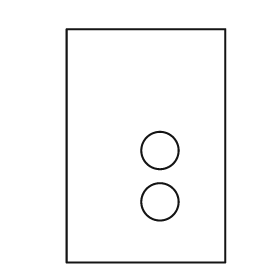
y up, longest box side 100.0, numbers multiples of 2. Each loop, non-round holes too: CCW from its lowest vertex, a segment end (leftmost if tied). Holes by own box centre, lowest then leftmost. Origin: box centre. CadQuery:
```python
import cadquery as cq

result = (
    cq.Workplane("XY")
    .moveTo(-34.0, -50.0)
    .lineTo(34.0, -50.0)
    .lineTo(34.0, 50.0)
    .lineTo(-34.0, 50.0)
    .close()
    .moveTo(6.0, -24.0)
    .circle(8.0)
    .moveTo(6.0, -2.0)
    .circle(8.0)
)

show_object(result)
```